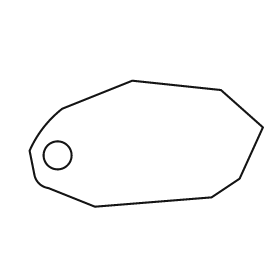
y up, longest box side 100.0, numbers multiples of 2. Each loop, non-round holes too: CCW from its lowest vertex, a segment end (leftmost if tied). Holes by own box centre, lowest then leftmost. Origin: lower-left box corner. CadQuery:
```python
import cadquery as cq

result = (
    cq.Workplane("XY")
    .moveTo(28.0, 0.0)
    .lineTo(78.0, 4.0)
    .lineTo(90.0, 12.0)
    .lineTo(100.0, 34.0)
    .lineTo(82.0, 50.0)
    .lineTo(44.0, 54.0)
    .lineTo(14.0, 42.0)
    .threePointArc((6.0, 34.0), (0.0, 24.0))
    .lineTo(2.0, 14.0)
    .threePointArc((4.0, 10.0), (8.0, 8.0))
    .close()
    .moveTo(12.0, 22.0)
    .circle(6.0)
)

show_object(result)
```